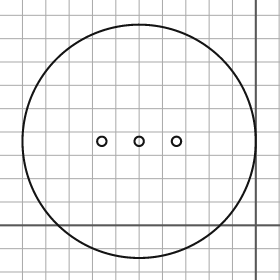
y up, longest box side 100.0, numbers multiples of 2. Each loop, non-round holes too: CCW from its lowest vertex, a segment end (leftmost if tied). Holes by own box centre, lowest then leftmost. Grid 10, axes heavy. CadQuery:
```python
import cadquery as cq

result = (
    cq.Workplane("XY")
    .moveTo(-50.0, 36.0)
    .circle(50.0)
    .moveTo(-66.0, 36.0)
    .circle(2.0)
    .moveTo(-50.0, 36.0)
    .circle(2.0)
    .moveTo(-34.0, 36.0)
    .circle(2.0)
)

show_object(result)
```